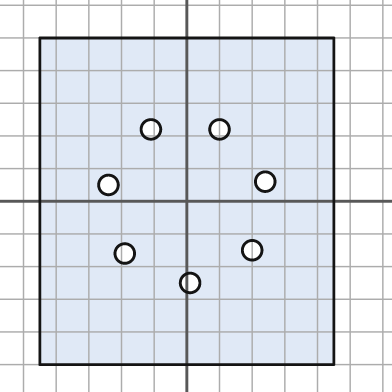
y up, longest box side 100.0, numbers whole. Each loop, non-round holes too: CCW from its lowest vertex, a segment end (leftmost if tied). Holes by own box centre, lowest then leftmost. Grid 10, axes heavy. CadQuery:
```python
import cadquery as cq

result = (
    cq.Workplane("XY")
    .moveTo(-45.0, -50.0)
    .lineTo(45.0, -50.0)
    .lineTo(45.0, 50.0)
    .lineTo(-45.0, 50.0)
    .close()
    .moveTo(1.0, -25.0)
    .circle(3.0)
    .moveTo(-19.0, -16.0)
    .circle(3.0)
    .moveTo(20.0, -15.0)
    .circle(3.0)
    .moveTo(-24.0, 5.0)
    .circle(3.0)
    .moveTo(24.0, 6.0)
    .circle(3.0)
    .moveTo(-11.0, 22.0)
    .circle(3.0)
    .moveTo(10.0, 22.0)
    .circle(3.0)
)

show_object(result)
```